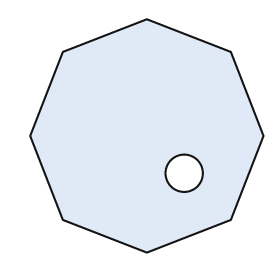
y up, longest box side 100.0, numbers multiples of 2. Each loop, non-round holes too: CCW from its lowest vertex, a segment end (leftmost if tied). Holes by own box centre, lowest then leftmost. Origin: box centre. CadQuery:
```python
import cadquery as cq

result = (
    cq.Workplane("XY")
    .moveTo(0.0, -50.0)
    .lineTo(36.0, -36.0)
    .lineTo(50.0, 0.0)
    .lineTo(36.0, 36.0)
    .lineTo(0.0, 50.0)
    .lineTo(-36.0, 36.0)
    .lineTo(-50.0, 0.0)
    .lineTo(-36.0, -36.0)
    .close()
    .moveTo(16.0, -16.0)
    .circle(8.0)
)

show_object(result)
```